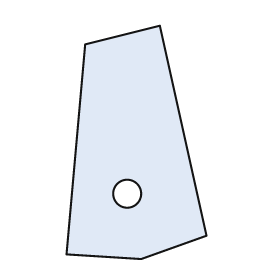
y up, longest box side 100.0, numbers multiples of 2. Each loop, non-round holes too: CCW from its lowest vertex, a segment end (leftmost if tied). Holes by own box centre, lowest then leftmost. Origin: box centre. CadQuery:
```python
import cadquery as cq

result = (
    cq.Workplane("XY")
    .moveTo(2.0, -50.0)
    .lineTo(30.0, -40.0)
    .lineTo(10.0, 50.0)
    .lineTo(-22.0, 42.0)
    .lineTo(-30.0, -48.0)
    .close()
    .moveTo(-4.0, -22.0)
    .circle(6.0)
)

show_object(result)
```